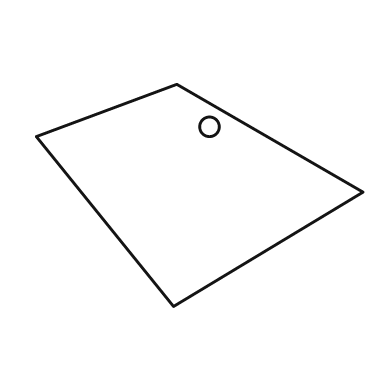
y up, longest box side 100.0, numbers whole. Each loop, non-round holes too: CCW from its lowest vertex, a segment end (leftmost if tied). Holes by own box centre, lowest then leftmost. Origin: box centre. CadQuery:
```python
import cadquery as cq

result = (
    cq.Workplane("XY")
    .moveTo(-8.0, -34.0)
    .lineTo(50.0, 1.0)
    .lineTo(-7.0, 34.0)
    .lineTo(-50.0, 18.0)
    .close()
    .moveTo(3.0, 21.0)
    .circle(3.0)
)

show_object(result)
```